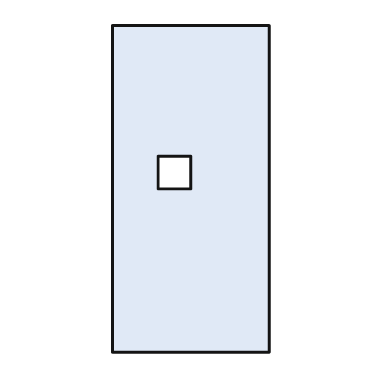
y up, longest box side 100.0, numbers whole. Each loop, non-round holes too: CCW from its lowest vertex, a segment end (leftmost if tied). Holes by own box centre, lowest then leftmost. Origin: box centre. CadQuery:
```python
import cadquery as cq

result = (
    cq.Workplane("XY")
    .moveTo(-24.0, -50.0)
    .lineTo(24.0, -50.0)
    .lineTo(24.0, 50.0)
    .lineTo(-24.0, 50.0)
    .close()
    .moveTo(-10.0, 0.0)
    .lineTo(0.0, 0.0)
    .lineTo(0.0, 10.0)
    .lineTo(-10.0, 10.0)
    .close()
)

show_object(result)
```